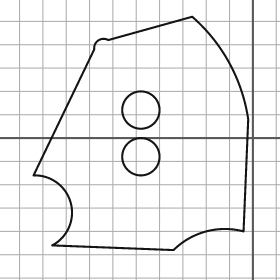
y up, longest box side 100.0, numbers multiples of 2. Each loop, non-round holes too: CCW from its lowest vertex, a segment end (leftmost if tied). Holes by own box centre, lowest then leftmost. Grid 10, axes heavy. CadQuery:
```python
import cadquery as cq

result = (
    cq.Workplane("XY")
    .moveTo(-34.0, -48.0)
    .threePointArc((-20.0, -40.0), (-4.0, -40.0))
    .lineTo(-2.0, 8.0)
    .threePointArc((-10.0, 32.0), (-26.0, 52.0))
    .lineTo(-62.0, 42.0)
    .threePointArc((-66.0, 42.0), (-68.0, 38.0))
    .lineTo(-94.0, -16.0)
    .threePointArc((-78.0, -28.0), (-86.0, -46.0))
    .close()
    .moveTo(-48.0, -8.0)
    .circle(8.0)
    .moveTo(-48.0, 12.0)
    .circle(8.0)
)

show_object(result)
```